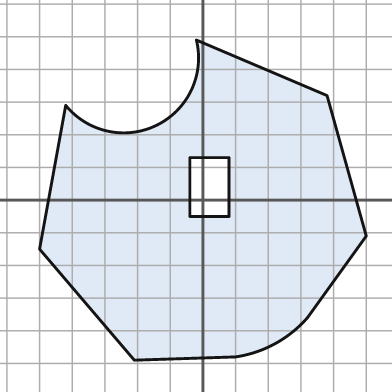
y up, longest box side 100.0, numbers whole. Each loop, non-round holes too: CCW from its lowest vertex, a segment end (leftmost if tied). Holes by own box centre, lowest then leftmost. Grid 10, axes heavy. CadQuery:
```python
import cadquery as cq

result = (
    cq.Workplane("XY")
    .moveTo(-21.0, -49.0)
    .lineTo(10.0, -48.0)
    .threePointArc((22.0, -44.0), (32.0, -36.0))
    .lineTo(50.0, -11.0)
    .lineTo(38.0, 32.0)
    .lineTo(-2.0, 49.0)
    .threePointArc((-14.0, 23.0), (-42.0, 29.0))
    .lineTo(-50.0, -15.0)
    .close()
    .moveTo(-4.0, -5.0)
    .lineTo(8.0, -5.0)
    .lineTo(8.0, 13.0)
    .lineTo(-4.0, 13.0)
    .close()
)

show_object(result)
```